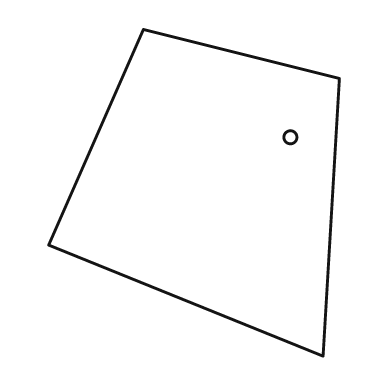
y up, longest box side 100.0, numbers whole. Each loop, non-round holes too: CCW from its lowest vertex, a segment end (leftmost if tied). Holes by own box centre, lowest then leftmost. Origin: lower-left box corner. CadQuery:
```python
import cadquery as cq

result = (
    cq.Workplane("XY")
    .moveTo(84.0, 0.0)
    .lineTo(89.0, 85.0)
    .lineTo(29.0, 100.0)
    .lineTo(0.0, 34.0)
    .close()
    .moveTo(74.0, 67.0)
    .circle(2.0)
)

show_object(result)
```